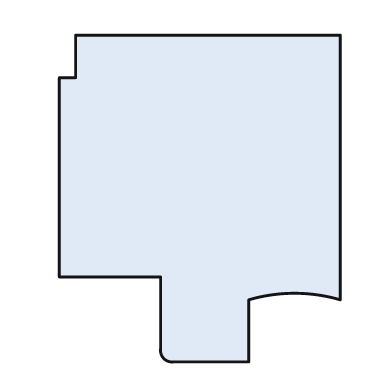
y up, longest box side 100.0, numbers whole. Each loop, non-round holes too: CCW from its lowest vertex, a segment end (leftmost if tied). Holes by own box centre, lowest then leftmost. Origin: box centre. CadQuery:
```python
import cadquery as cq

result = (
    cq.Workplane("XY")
    .moveTo(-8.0, -50.0)
    .lineTo(15.0, -50.0)
    .lineTo(15.0, -31.0)
    .threePointArc((29.0, -29.0), (43.0, -31.0))
    .lineTo(43.0, 50.0)
    .lineTo(-38.0, 50.0)
    .lineTo(-38.0, 37.0)
    .lineTo(-43.0, 37.0)
    .lineTo(-43.0, -24.0)
    .lineTo(-12.0, -24.0)
    .lineTo(-12.0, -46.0)
    .threePointArc((-11.0, -49.0), (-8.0, -50.0))
    .close()
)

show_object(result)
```